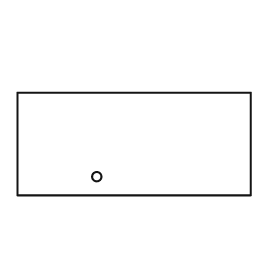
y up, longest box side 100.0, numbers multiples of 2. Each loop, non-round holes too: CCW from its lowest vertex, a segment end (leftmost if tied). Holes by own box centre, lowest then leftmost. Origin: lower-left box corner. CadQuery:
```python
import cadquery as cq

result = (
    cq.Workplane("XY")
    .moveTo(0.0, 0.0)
    .lineTo(100.0, 0.0)
    .lineTo(100.0, 44.0)
    .lineTo(0.0, 44.0)
    .close()
    .moveTo(34.0, 8.0)
    .circle(2.0)
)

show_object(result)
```